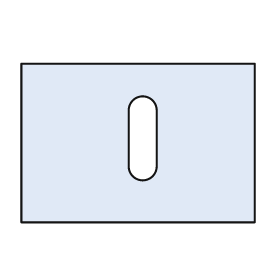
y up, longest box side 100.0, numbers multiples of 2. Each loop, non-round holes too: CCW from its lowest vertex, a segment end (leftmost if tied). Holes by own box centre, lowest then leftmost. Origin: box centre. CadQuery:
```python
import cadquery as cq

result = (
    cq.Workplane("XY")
    .moveTo(-50.0, -34.0)
    .lineTo(50.0, -34.0)
    .lineTo(50.0, 34.0)
    .lineTo(-50.0, 34.0)
    .close()
    .moveTo(-4.0, -10.0)
    .threePointArc((2.0, -16.0), (8.0, -10.0))
    .lineTo(8.0, 14.0)
    .threePointArc((2.0, 20.0), (-4.0, 14.0))
    .close()
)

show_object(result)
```